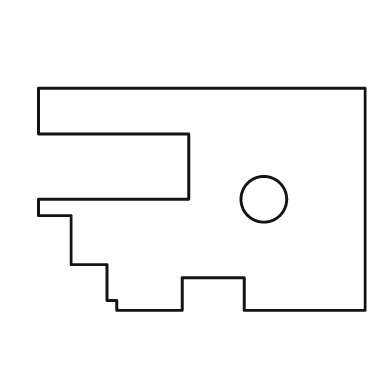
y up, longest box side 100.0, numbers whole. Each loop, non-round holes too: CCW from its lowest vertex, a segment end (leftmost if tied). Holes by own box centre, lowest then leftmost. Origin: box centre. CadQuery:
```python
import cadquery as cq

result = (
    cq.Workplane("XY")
    .moveTo(-26.0, -34.0)
    .lineTo(-6.0, -34.0)
    .lineTo(-6.0, -24.0)
    .lineTo(13.0, -24.0)
    .lineTo(13.0, -34.0)
    .lineTo(50.0, -34.0)
    .lineTo(50.0, 34.0)
    .lineTo(-50.0, 34.0)
    .lineTo(-50.0, 20.0)
    .lineTo(-4.0, 20.0)
    .lineTo(-4.0, 0.0)
    .lineTo(-50.0, 0.0)
    .lineTo(-50.0, -5.0)
    .lineTo(-40.0, -5.0)
    .lineTo(-40.0, -20.0)
    .lineTo(-29.0, -20.0)
    .lineTo(-29.0, -31.0)
    .lineTo(-26.0, -31.0)
    .close()
    .moveTo(19.0, 0.0)
    .circle(7.0)
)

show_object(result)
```